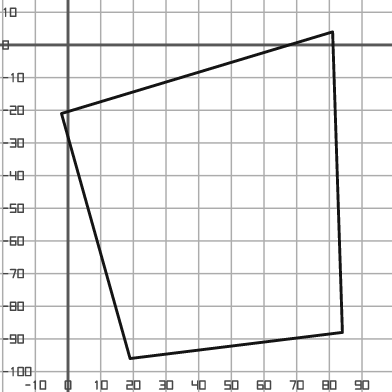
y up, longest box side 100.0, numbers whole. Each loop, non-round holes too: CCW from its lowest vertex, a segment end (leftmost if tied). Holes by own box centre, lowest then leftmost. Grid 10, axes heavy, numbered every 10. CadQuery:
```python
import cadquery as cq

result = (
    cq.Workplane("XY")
    .moveTo(19.0, -96.0)
    .lineTo(84.0, -88.0)
    .lineTo(81.0, 4.0)
    .lineTo(-2.0, -21.0)
    .close()
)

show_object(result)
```